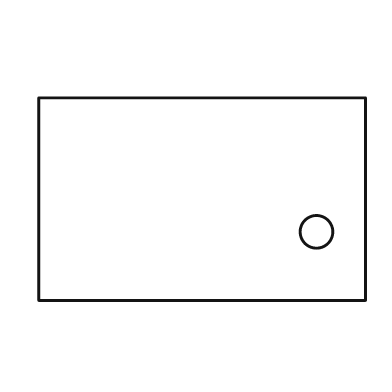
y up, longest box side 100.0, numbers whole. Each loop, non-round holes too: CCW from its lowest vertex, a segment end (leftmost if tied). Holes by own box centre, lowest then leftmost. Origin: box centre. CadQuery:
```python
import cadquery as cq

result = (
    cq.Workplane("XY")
    .moveTo(-50.0, -31.0)
    .lineTo(50.0, -31.0)
    .lineTo(50.0, 31.0)
    .lineTo(-50.0, 31.0)
    .close()
    .moveTo(35.0, -10.0)
    .circle(5.0)
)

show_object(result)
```